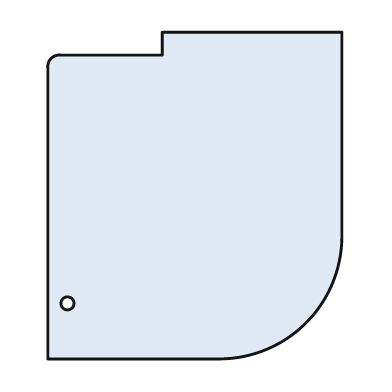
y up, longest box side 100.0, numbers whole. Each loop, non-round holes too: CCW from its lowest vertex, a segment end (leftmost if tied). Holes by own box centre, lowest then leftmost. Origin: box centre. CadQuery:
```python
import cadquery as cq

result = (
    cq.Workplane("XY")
    .moveTo(-45.0, -50.0)
    .lineTo(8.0, -50.0)
    .threePointArc((34.0, -39.0), (45.0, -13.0))
    .lineTo(45.0, 50.0)
    .lineTo(-10.0, 50.0)
    .lineTo(-10.0, 43.0)
    .lineTo(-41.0, 43.0)
    .threePointArc((-44.0, 42.0), (-45.0, 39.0))
    .close()
    .moveTo(-39.0, -33.0)
    .circle(2.0)
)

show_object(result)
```